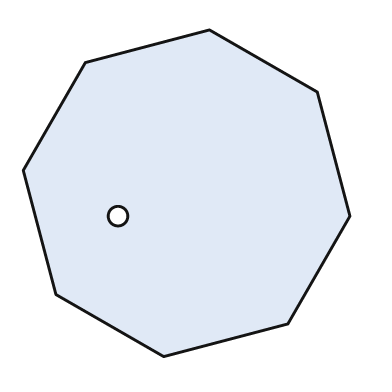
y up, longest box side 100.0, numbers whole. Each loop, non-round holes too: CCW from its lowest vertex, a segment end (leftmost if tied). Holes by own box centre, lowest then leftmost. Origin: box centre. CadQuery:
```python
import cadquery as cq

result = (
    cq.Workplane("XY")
    .moveTo(-7.0, -50.0)
    .lineTo(31.0, -40.0)
    .lineTo(50.0, -7.0)
    .lineTo(40.0, 31.0)
    .lineTo(7.0, 50.0)
    .lineTo(-31.0, 40.0)
    .lineTo(-50.0, 7.0)
    .lineTo(-40.0, -31.0)
    .close()
    .moveTo(-21.0, -7.0)
    .circle(3.0)
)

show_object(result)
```